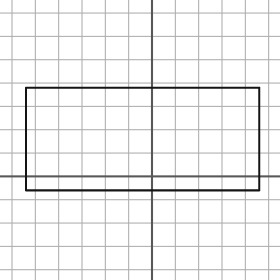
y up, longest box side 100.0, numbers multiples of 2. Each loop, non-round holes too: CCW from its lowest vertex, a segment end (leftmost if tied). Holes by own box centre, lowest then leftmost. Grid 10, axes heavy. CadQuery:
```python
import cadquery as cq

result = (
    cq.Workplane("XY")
    .moveTo(-54.0, -6.0)
    .lineTo(46.0, -6.0)
    .lineTo(46.0, 38.0)
    .lineTo(-54.0, 38.0)
    .close()
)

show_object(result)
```